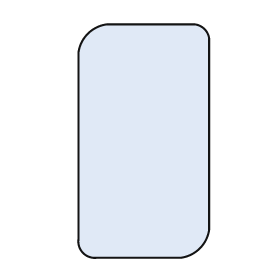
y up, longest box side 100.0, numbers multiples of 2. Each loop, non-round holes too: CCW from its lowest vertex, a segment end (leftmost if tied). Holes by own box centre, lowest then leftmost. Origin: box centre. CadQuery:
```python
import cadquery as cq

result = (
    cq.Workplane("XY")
    .moveTo(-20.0, -50.0)
    .lineTo(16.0, -50.0)
    .threePointArc((24.0, -46.0), (28.0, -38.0))
    .lineTo(28.0, 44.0)
    .threePointArc((26.0, 48.0), (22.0, 50.0))
    .lineTo(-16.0, 50.0)
    .threePointArc((-24.0, 46.0), (-28.0, 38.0))
    .lineTo(-28.0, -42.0)
    .threePointArc((-26.0, -48.0), (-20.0, -50.0))
    .close()
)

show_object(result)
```